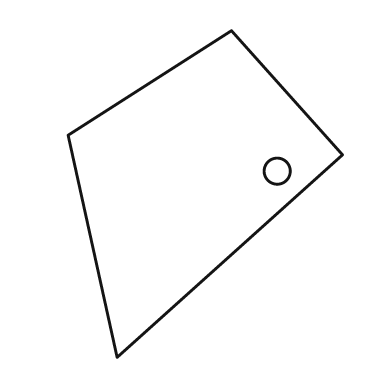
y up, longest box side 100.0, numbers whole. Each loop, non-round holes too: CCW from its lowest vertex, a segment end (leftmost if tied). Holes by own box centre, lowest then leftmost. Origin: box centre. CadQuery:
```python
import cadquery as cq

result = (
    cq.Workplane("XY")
    .moveTo(-27.0, -50.0)
    .lineTo(42.0, 12.0)
    .lineTo(8.0, 50.0)
    .lineTo(-42.0, 18.0)
    .close()
    .moveTo(22.0, 7.0)
    .circle(4.0)
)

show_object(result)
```